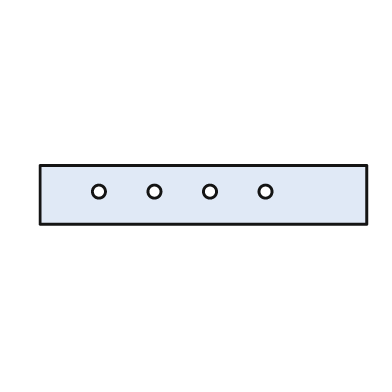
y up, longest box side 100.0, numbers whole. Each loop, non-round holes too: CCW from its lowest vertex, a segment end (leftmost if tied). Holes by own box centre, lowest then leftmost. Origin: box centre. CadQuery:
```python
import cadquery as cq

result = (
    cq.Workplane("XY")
    .moveTo(-50.0, -9.0)
    .lineTo(50.0, -9.0)
    .lineTo(50.0, 9.0)
    .lineTo(-50.0, 9.0)
    .close()
    .moveTo(-32.0, 1.0)
    .circle(2.0)
    .moveTo(-15.0, 1.0)
    .circle(2.0)
    .moveTo(2.0, 1.0)
    .circle(2.0)
    .moveTo(19.0, 1.0)
    .circle(2.0)
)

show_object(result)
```